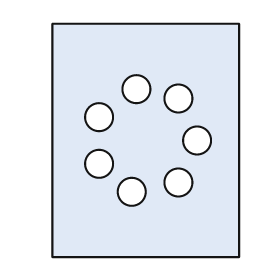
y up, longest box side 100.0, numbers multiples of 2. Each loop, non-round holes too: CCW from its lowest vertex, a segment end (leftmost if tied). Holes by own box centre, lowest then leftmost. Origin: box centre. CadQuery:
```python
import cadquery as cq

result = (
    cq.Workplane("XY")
    .moveTo(-40.0, -50.0)
    .lineTo(40.0, -50.0)
    .lineTo(40.0, 50.0)
    .lineTo(-40.0, 50.0)
    .close()
    .moveTo(-6.0, -22.0)
    .circle(6.0)
    .moveTo(14.0, -18.0)
    .circle(6.0)
    .moveTo(-20.0, -10.0)
    .circle(6.0)
    .moveTo(22.0, 0.0)
    .circle(6.0)
    .moveTo(-20.0, 10.0)
    .circle(6.0)
    .moveTo(14.0, 18.0)
    .circle(6.0)
    .moveTo(-4.0, 22.0)
    .circle(6.0)
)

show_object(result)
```